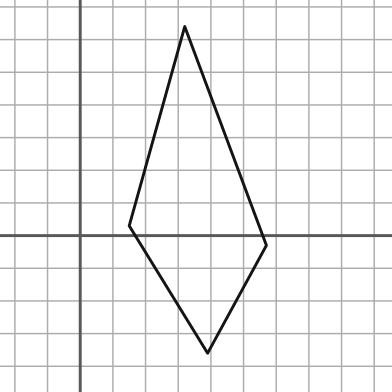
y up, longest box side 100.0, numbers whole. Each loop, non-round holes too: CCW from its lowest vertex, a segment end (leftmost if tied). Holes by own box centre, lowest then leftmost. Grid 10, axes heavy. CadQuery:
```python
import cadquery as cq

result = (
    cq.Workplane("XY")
    .moveTo(39.0, -36.0)
    .lineTo(57.0, -3.0)
    .lineTo(32.0, 64.0)
    .lineTo(15.0, 3.0)
    .close()
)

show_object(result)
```